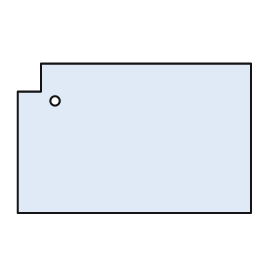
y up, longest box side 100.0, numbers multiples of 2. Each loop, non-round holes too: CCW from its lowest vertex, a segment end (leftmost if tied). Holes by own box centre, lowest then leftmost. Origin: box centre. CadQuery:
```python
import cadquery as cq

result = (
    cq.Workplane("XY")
    .moveTo(-50.0, -32.0)
    .lineTo(50.0, -32.0)
    .lineTo(50.0, 32.0)
    .lineTo(-40.0, 32.0)
    .lineTo(-40.0, 20.0)
    .lineTo(-50.0, 20.0)
    .close()
    .moveTo(-34.0, 16.0)
    .circle(2.0)
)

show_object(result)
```